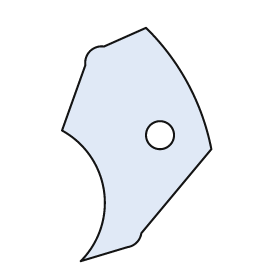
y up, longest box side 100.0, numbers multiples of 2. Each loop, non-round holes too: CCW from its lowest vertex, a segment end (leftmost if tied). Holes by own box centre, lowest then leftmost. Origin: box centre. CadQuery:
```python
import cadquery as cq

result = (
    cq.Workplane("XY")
    .moveTo(-24.0, -50.0)
    .lineTo(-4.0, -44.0)
    .threePointArc((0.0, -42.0), (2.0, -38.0))
    .lineTo(32.0, -2.0)
    .threePointArc((22.0, 26.0), (4.0, 50.0))
    .lineTo(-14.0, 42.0)
    .threePointArc((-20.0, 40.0), (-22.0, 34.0))
    .lineTo(-32.0, 6.0)
    .threePointArc((-14.0, -20.0), (-24.0, -50.0))
    .close()
    .moveTo(10.0, 4.0)
    .circle(6.0)
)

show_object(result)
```